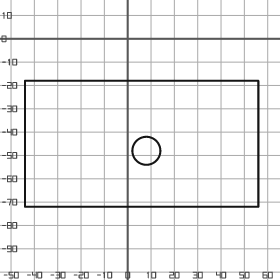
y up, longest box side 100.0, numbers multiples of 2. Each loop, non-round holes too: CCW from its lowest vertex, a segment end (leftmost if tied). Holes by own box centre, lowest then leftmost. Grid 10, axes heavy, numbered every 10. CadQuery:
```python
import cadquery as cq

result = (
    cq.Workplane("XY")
    .moveTo(-44.0, -72.0)
    .lineTo(56.0, -72.0)
    .lineTo(56.0, -18.0)
    .lineTo(-44.0, -18.0)
    .close()
    .moveTo(8.0, -48.0)
    .circle(6.0)
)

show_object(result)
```